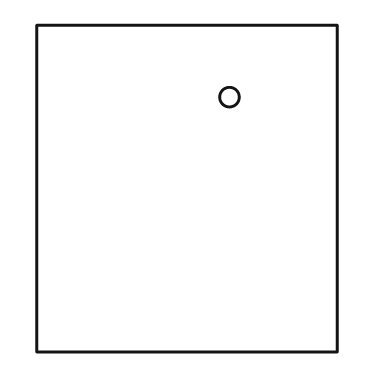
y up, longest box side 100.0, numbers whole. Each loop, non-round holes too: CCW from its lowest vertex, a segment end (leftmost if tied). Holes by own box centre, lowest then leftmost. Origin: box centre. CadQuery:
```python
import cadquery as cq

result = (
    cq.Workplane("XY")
    .moveTo(-46.0, -50.0)
    .lineTo(46.0, -50.0)
    .lineTo(46.0, 50.0)
    .lineTo(-46.0, 50.0)
    .close()
    .moveTo(13.0, 28.0)
    .circle(3.0)
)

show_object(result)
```